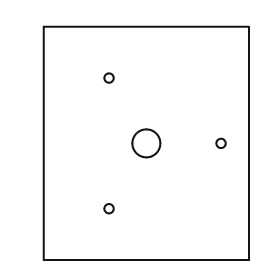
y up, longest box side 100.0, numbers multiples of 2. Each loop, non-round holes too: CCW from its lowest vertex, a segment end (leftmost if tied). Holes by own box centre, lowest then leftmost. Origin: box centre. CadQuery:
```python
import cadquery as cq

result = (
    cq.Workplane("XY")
    .moveTo(-44.0, -50.0)
    .lineTo(44.0, -50.0)
    .lineTo(44.0, 50.0)
    .lineTo(-44.0, 50.0)
    .close()
    .moveTo(-16.0, -28.0)
    .circle(2.0)
    .moveTo(0.0, 0.0)
    .circle(6.0)
    .moveTo(32.0, 0.0)
    .circle(2.0)
    .moveTo(-16.0, 28.0)
    .circle(2.0)
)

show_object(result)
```